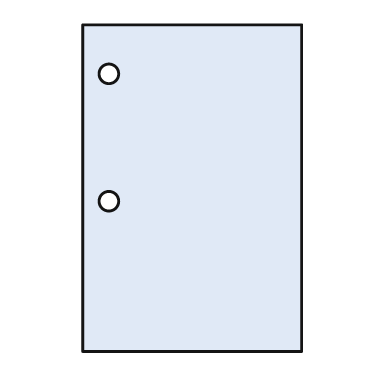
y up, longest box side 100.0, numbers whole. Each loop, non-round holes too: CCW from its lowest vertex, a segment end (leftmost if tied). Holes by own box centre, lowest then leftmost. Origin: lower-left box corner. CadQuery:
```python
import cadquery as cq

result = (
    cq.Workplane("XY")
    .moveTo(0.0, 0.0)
    .lineTo(67.0, 0.0)
    .lineTo(67.0, 100.0)
    .lineTo(0.0, 100.0)
    .close()
    .moveTo(8.0, 46.0)
    .circle(3.0)
    .moveTo(8.0, 85.0)
    .circle(3.0)
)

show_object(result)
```